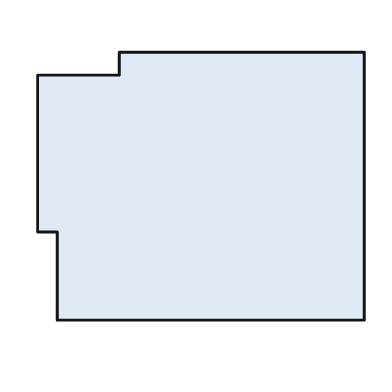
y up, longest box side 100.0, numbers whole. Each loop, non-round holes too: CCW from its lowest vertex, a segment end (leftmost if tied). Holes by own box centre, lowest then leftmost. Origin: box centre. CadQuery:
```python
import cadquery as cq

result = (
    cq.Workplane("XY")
    .moveTo(-44.0, -41.0)
    .lineTo(50.0, -41.0)
    .lineTo(50.0, 41.0)
    .lineTo(-25.0, 41.0)
    .lineTo(-25.0, 34.0)
    .lineTo(-50.0, 34.0)
    .lineTo(-50.0, -14.0)
    .lineTo(-44.0, -14.0)
    .close()
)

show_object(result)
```